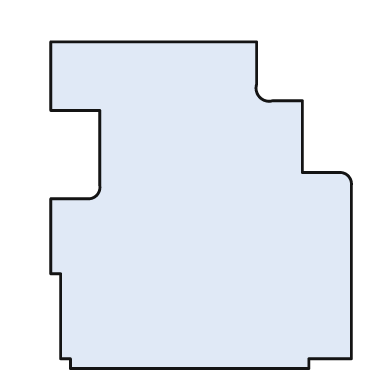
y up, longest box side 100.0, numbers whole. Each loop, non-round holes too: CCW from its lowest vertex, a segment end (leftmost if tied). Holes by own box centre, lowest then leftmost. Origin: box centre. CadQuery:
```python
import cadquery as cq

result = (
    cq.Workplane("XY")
    .moveTo(-40.0, -50.0)
    .lineTo(33.0, -50.0)
    .lineTo(33.0, -47.0)
    .lineTo(46.0, -47.0)
    .lineTo(46.0, 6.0)
    .threePointArc((45.0, 9.0), (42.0, 10.0))
    .lineTo(31.0, 10.0)
    .lineTo(31.0, 32.0)
    .lineTo(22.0, 32.0)
    .threePointArc((18.0, 33.0), (17.0, 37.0))
    .lineTo(17.0, 50.0)
    .lineTo(-46.0, 50.0)
    .lineTo(-46.0, 29.0)
    .lineTo(-31.0, 29.0)
    .lineTo(-31.0, 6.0)
    .threePointArc((-32.0, 3.0), (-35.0, 2.0))
    .lineTo(-46.0, 2.0)
    .lineTo(-46.0, -21.0)
    .lineTo(-43.0, -21.0)
    .lineTo(-43.0, -47.0)
    .lineTo(-40.0, -47.0)
    .close()
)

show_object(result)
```